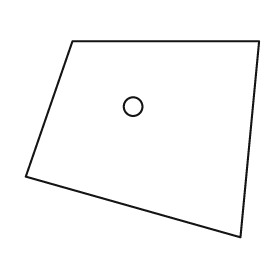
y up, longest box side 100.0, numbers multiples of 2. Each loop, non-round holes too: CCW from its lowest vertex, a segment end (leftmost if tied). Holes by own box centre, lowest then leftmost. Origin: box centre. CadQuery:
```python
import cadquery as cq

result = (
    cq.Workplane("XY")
    .moveTo(42.0, -42.0)
    .lineTo(50.0, 42.0)
    .lineTo(-30.0, 42.0)
    .lineTo(-50.0, -16.0)
    .close()
    .moveTo(-4.0, 14.0)
    .circle(4.0)
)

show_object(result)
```